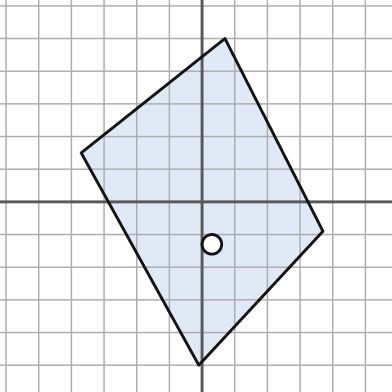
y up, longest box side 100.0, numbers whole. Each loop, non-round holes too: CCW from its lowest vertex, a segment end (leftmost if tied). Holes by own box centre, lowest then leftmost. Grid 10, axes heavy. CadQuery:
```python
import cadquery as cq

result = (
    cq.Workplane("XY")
    .moveTo(-1.0, -50.0)
    .lineTo(37.0, -9.0)
    .lineTo(7.0, 50.0)
    .lineTo(-37.0, 15.0)
    .close()
    .moveTo(3.0, -13.0)
    .circle(3.0)
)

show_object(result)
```